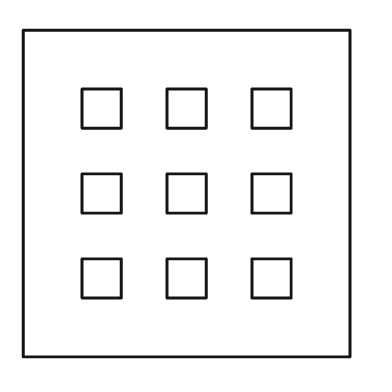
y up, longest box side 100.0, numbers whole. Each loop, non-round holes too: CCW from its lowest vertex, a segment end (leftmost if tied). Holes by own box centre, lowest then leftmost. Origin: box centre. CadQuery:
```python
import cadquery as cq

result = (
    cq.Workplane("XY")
    .moveTo(-50.0, -50.0)
    .lineTo(50.0, -50.0)
    .lineTo(50.0, 50.0)
    .lineTo(-50.0, 50.0)
    .close()
    .moveTo(-32.0, -32.0)
    .lineTo(-20.0, -32.0)
    .lineTo(-20.0, -20.0)
    .lineTo(-32.0, -20.0)
    .close()
    .moveTo(-6.0, -32.0)
    .lineTo(6.0, -32.0)
    .lineTo(6.0, -20.0)
    .lineTo(-6.0, -20.0)
    .close()
    .moveTo(20.0, -32.0)
    .lineTo(32.0, -32.0)
    .lineTo(32.0, -20.0)
    .lineTo(20.0, -20.0)
    .close()
    .moveTo(-32.0, -6.0)
    .lineTo(-20.0, -6.0)
    .lineTo(-20.0, 6.0)
    .lineTo(-32.0, 6.0)
    .close()
    .moveTo(-6.0, -6.0)
    .lineTo(6.0, -6.0)
    .lineTo(6.0, 6.0)
    .lineTo(-6.0, 6.0)
    .close()
    .moveTo(20.0, -6.0)
    .lineTo(32.0, -6.0)
    .lineTo(32.0, 6.0)
    .lineTo(20.0, 6.0)
    .close()
    .moveTo(-32.0, 20.0)
    .lineTo(-20.0, 20.0)
    .lineTo(-20.0, 32.0)
    .lineTo(-32.0, 32.0)
    .close()
    .moveTo(-6.0, 20.0)
    .lineTo(6.0, 20.0)
    .lineTo(6.0, 32.0)
    .lineTo(-6.0, 32.0)
    .close()
    .moveTo(20.0, 20.0)
    .lineTo(32.0, 20.0)
    .lineTo(32.0, 32.0)
    .lineTo(20.0, 32.0)
    .close()
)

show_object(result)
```